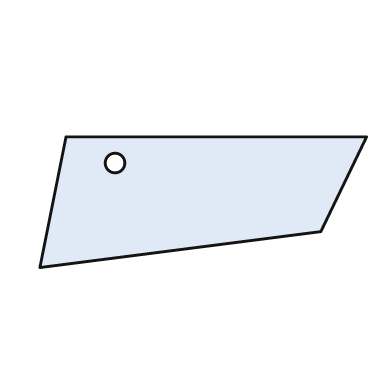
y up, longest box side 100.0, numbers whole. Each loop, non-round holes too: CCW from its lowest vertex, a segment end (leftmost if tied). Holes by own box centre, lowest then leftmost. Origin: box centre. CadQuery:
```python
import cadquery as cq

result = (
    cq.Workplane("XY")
    .moveTo(-50.0, -20.0)
    .lineTo(36.0, -9.0)
    .lineTo(50.0, 20.0)
    .lineTo(-42.0, 20.0)
    .close()
    .moveTo(-27.0, 12.0)
    .circle(3.0)
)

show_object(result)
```